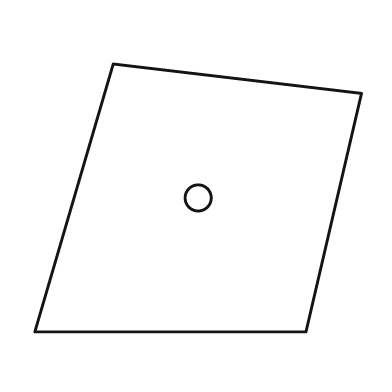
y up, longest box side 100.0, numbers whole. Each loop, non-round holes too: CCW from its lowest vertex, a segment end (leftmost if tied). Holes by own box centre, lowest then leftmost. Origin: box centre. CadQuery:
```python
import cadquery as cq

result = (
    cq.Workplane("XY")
    .moveTo(-50.0, -41.0)
    .lineTo(33.0, -41.0)
    .lineTo(50.0, 32.0)
    .lineTo(-26.0, 41.0)
    .close()
    .moveTo(0.0, 0.0)
    .circle(4.0)
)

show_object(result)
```